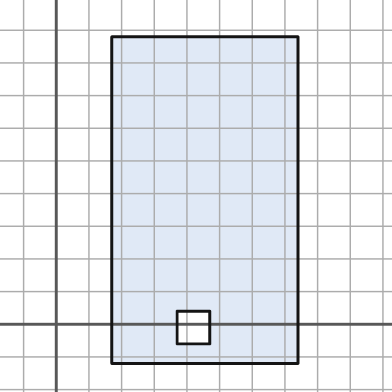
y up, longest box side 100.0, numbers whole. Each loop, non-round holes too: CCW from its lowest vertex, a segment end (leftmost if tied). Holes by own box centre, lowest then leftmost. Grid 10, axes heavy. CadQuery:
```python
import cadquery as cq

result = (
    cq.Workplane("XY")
    .moveTo(17.0, -12.0)
    .lineTo(74.0, -12.0)
    .lineTo(74.0, 88.0)
    .lineTo(17.0, 88.0)
    .close()
    .moveTo(37.0, -6.0)
    .lineTo(47.0, -6.0)
    .lineTo(47.0, 4.0)
    .lineTo(37.0, 4.0)
    .close()
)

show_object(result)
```